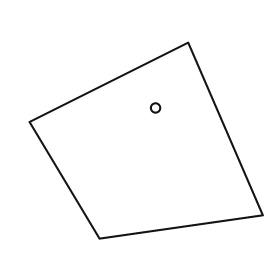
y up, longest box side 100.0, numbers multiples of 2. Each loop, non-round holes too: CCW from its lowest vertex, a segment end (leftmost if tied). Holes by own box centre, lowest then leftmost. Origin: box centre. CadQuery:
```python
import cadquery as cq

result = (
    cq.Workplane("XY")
    .moveTo(-20.0, -42.0)
    .lineTo(50.0, -32.0)
    .lineTo(18.0, 42.0)
    .lineTo(-50.0, 8.0)
    .close()
    .moveTo(4.0, 14.0)
    .circle(2.0)
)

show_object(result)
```